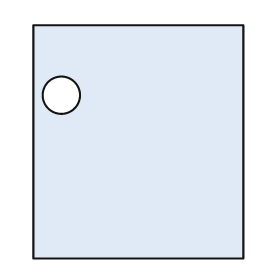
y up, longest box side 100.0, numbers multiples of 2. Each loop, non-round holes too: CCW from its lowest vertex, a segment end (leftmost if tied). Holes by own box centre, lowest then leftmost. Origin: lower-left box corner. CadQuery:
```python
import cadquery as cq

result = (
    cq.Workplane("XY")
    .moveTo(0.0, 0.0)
    .lineTo(90.0, 0.0)
    .lineTo(90.0, 100.0)
    .lineTo(0.0, 100.0)
    .close()
    .moveTo(12.0, 70.0)
    .circle(8.0)
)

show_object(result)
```